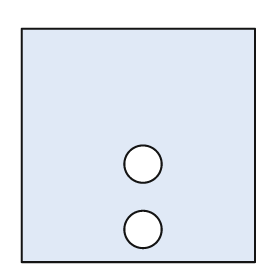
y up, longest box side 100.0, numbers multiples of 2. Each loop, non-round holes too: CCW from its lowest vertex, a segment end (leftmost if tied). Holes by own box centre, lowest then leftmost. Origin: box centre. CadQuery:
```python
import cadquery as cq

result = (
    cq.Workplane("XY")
    .moveTo(-50.0, -50.0)
    .lineTo(50.0, -50.0)
    .lineTo(50.0, 50.0)
    .lineTo(-50.0, 50.0)
    .close()
    .moveTo(2.0, -36.0)
    .circle(8.0)
    .moveTo(2.0, -8.0)
    .circle(8.0)
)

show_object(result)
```